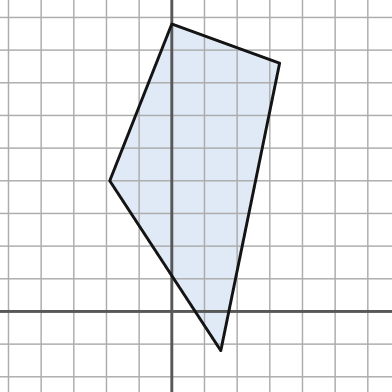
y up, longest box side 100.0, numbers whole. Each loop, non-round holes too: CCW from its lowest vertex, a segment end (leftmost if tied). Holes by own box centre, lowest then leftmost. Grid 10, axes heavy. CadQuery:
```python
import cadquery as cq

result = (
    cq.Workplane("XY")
    .moveTo(15.0, -12.0)
    .lineTo(33.0, 76.0)
    .lineTo(0.0, 88.0)
    .lineTo(-19.0, 40.0)
    .close()
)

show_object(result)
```